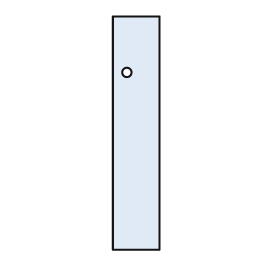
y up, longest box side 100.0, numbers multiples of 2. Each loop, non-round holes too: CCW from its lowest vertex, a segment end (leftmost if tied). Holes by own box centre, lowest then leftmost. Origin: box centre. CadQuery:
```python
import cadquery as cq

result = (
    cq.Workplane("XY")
    .moveTo(-10.0, -50.0)
    .lineTo(10.0, -50.0)
    .lineTo(10.0, 50.0)
    .lineTo(-10.0, 50.0)
    .close()
    .moveTo(-4.0, 26.0)
    .circle(2.0)
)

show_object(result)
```